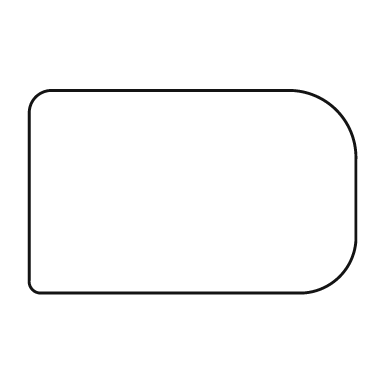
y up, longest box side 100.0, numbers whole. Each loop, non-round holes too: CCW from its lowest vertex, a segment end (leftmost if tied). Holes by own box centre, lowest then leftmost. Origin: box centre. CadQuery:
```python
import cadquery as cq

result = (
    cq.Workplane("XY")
    .moveTo(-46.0, -31.0)
    .lineTo(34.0, -31.0)
    .threePointArc((45.0, -26.0), (50.0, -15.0))
    .lineTo(50.0, 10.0)
    .threePointArc((44.0, 25.0), (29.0, 31.0))
    .lineTo(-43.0, 31.0)
    .threePointArc((-48.0, 29.0), (-50.0, 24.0))
    .lineTo(-50.0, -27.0)
    .threePointArc((-49.0, -30.0), (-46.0, -31.0))
    .close()
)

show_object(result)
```